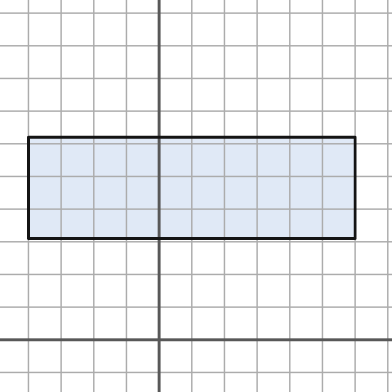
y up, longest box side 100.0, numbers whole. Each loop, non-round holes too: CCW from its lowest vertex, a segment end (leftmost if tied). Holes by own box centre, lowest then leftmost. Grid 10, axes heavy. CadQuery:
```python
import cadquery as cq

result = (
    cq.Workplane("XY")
    .moveTo(-40.0, 31.0)
    .lineTo(60.0, 31.0)
    .lineTo(60.0, 62.0)
    .lineTo(-40.0, 62.0)
    .close()
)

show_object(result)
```